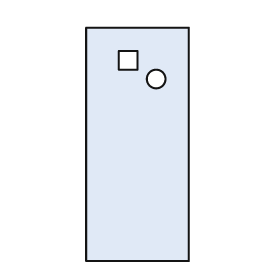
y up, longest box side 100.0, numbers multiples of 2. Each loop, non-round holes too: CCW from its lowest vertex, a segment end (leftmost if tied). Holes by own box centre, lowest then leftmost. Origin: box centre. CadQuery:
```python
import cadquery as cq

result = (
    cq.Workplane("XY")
    .moveTo(-22.0, -50.0)
    .lineTo(22.0, -50.0)
    .lineTo(22.0, 50.0)
    .lineTo(-22.0, 50.0)
    .close()
    .moveTo(8.0, 28.0)
    .circle(4.0)
    .moveTo(-8.0, 32.0)
    .lineTo(0.0, 32.0)
    .lineTo(0.0, 40.0)
    .lineTo(-8.0, 40.0)
    .close()
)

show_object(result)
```